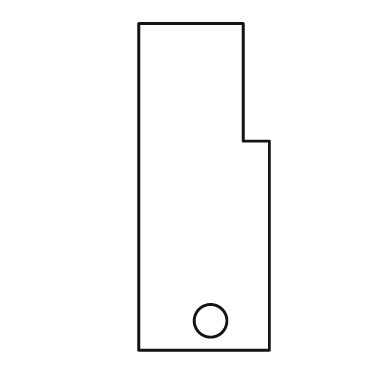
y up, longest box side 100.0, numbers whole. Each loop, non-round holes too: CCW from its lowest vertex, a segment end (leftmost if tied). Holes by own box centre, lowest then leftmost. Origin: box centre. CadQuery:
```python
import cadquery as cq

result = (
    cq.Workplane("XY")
    .moveTo(-20.0, -50.0)
    .lineTo(20.0, -50.0)
    .lineTo(20.0, 14.0)
    .lineTo(12.0, 14.0)
    .lineTo(12.0, 50.0)
    .lineTo(-20.0, 50.0)
    .close()
    .moveTo(2.0, -41.0)
    .circle(5.0)
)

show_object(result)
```